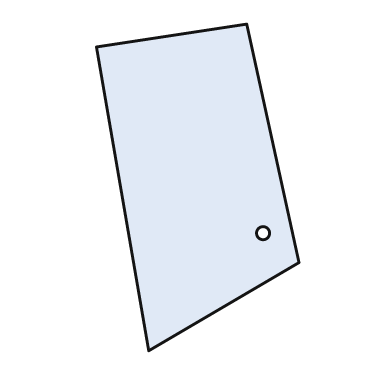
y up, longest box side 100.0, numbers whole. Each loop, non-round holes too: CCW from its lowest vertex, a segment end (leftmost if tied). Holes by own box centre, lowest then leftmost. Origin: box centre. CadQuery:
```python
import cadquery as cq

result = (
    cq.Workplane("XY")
    .moveTo(-15.0, -50.0)
    .lineTo(31.0, -23.0)
    .lineTo(15.0, 50.0)
    .lineTo(-31.0, 43.0)
    .close()
    .moveTo(20.0, -14.0)
    .circle(2.0)
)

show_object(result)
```